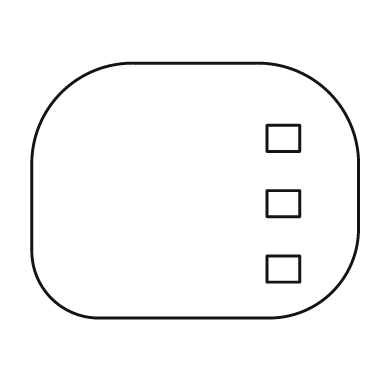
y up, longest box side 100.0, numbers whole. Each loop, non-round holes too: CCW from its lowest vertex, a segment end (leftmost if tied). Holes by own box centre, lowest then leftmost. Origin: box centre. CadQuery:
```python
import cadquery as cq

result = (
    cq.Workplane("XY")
    .moveTo(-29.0, -39.0)
    .lineTo(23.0, -39.0)
    .threePointArc((42.0, -31.0), (50.0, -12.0))
    .lineTo(50.0, 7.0)
    .threePointArc((41.0, 30.0), (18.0, 39.0))
    .lineTo(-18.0, 39.0)
    .threePointArc((-41.0, 30.0), (-50.0, 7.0))
    .lineTo(-50.0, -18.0)
    .threePointArc((-44.0, -33.0), (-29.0, -39.0))
    .close()
    .moveTo(22.0, -28.0)
    .lineTo(32.0, -28.0)
    .lineTo(32.0, -20.0)
    .lineTo(22.0, -20.0)
    .close()
    .moveTo(22.0, -8.0)
    .lineTo(32.0, -8.0)
    .lineTo(32.0, 0.0)
    .lineTo(22.0, 0.0)
    .close()
    .moveTo(22.0, 12.0)
    .lineTo(32.0, 12.0)
    .lineTo(32.0, 20.0)
    .lineTo(22.0, 20.0)
    .close()
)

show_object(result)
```